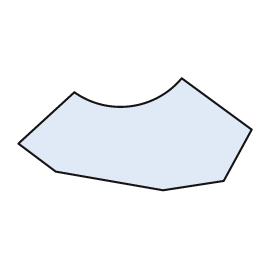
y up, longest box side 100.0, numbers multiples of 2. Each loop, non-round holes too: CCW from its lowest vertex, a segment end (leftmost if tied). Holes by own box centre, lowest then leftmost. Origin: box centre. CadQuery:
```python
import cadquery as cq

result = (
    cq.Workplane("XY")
    .moveTo(12.0, -24.0)
    .lineTo(38.0, -20.0)
    .lineTo(50.0, 2.0)
    .lineTo(20.0, 24.0)
    .threePointArc((-2.0, 12.0), (-26.0, 18.0))
    .lineTo(-50.0, -4.0)
    .lineTo(-34.0, -16.0)
    .close()
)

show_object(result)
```